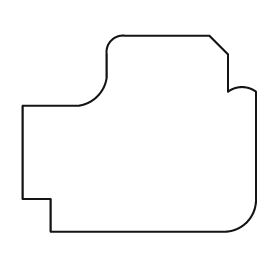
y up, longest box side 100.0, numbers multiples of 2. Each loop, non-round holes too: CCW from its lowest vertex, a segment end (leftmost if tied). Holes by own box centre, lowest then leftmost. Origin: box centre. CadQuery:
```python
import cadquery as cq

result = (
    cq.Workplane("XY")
    .moveTo(-38.0, -42.0)
    .lineTo(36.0, -42.0)
    .threePointArc((46.0, -38.0), (50.0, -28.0))
    .lineTo(50.0, 18.0)
    .threePointArc((44.0, 20.0), (38.0, 18.0))
    .lineTo(38.0, 34.0)
    .lineTo(30.0, 42.0)
    .lineTo(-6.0, 42.0)
    .threePointArc((-12.0, 40.0), (-14.0, 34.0))
    .lineTo(-14.0, 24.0)
    .threePointArc((-18.0, 16.0), (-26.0, 12.0))
    .lineTo(-50.0, 12.0)
    .lineTo(-50.0, -28.0)
    .lineTo(-38.0, -28.0)
    .close()
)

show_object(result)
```